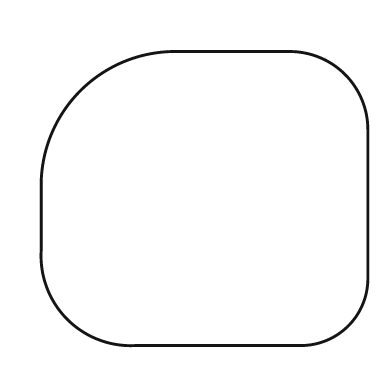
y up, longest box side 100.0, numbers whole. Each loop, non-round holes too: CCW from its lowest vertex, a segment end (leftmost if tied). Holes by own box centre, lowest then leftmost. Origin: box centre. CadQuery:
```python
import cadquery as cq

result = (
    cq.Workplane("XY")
    .moveTo(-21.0, -45.0)
    .lineTo(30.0, -45.0)
    .threePointArc((44.0, -39.0), (50.0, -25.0))
    .lineTo(50.0, 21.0)
    .threePointArc((43.0, 38.0), (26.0, 45.0))
    .lineTo(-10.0, 45.0)
    .threePointArc((-38.0, 33.0), (-50.0, 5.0))
    .lineTo(-50.0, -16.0)
    .threePointArc((-42.0, -37.0), (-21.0, -45.0))
    .close()
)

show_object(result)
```